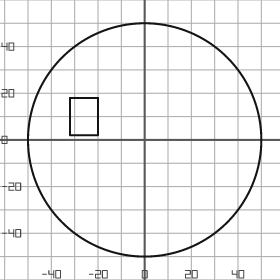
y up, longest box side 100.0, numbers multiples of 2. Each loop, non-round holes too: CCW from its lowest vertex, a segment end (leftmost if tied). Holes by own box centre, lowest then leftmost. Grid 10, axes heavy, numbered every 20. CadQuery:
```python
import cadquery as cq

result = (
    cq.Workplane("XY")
    .moveTo(0.0, 0.0)
    .circle(50.0)
    .moveTo(-32.0, 2.0)
    .lineTo(-20.0, 2.0)
    .lineTo(-20.0, 18.0)
    .lineTo(-32.0, 18.0)
    .close()
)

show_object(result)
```